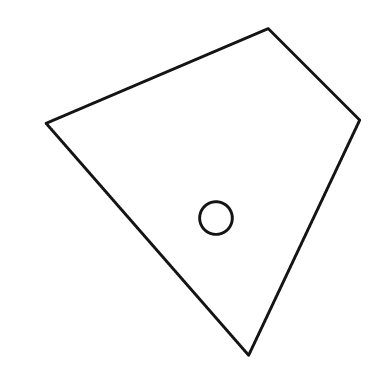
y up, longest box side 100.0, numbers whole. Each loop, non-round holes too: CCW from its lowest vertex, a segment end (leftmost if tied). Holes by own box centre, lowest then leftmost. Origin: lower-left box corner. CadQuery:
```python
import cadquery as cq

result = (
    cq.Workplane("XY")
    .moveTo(62.0, 0.0)
    .lineTo(96.0, 72.0)
    .lineTo(68.0, 100.0)
    .lineTo(0.0, 71.0)
    .close()
    .moveTo(52.0, 42.0)
    .circle(5.0)
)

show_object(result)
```